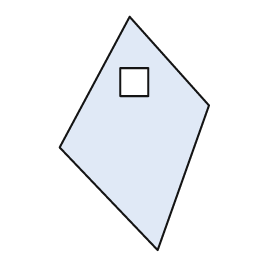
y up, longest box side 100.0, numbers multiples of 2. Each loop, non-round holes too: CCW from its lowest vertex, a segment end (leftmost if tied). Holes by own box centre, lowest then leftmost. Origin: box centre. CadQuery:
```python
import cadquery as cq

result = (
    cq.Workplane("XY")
    .moveTo(10.0, -50.0)
    .lineTo(32.0, 12.0)
    .lineTo(-2.0, 50.0)
    .lineTo(-32.0, -6.0)
    .close()
    .moveTo(-6.0, 16.0)
    .lineTo(6.0, 16.0)
    .lineTo(6.0, 28.0)
    .lineTo(-6.0, 28.0)
    .close()
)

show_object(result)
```